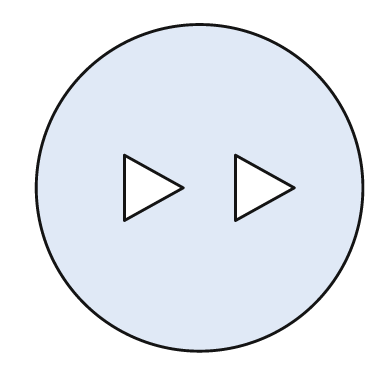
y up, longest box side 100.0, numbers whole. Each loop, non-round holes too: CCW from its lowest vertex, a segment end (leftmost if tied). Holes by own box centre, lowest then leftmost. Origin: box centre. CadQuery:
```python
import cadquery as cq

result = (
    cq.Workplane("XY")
    .moveTo(0.0, 0.0)
    .circle(50.0)
    .moveTo(-23.0, -10.0)
    .lineTo(-5.0, 0.0)
    .lineTo(-23.0, 10.0)
    .close()
    .moveTo(11.0, -10.0)
    .lineTo(29.0, 0.0)
    .lineTo(11.0, 10.0)
    .close()
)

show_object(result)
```